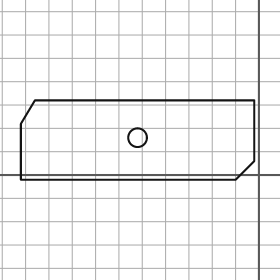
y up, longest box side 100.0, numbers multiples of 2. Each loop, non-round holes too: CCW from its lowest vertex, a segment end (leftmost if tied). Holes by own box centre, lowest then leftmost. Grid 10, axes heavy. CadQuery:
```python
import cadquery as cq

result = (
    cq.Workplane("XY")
    .moveTo(-102.0, -2.0)
    .lineTo(-10.0, -2.0)
    .lineTo(-2.0, 6.0)
    .lineTo(-2.0, 32.0)
    .lineTo(-96.0, 32.0)
    .lineTo(-102.0, 22.0)
    .close()
    .moveTo(-52.0, 16.0)
    .circle(4.0)
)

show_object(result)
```